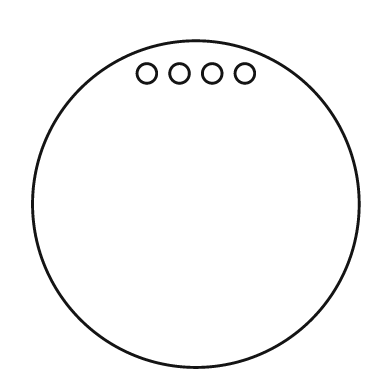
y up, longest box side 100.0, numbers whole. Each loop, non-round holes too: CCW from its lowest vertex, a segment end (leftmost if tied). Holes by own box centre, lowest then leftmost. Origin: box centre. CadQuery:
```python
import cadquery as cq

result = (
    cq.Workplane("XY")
    .moveTo(0.0, 0.0)
    .circle(50.0)
    .moveTo(-15.0, 40.0)
    .circle(3.0)
    .moveTo(-5.0, 40.0)
    .circle(3.0)
    .moveTo(5.0, 40.0)
    .circle(3.0)
    .moveTo(15.0, 40.0)
    .circle(3.0)
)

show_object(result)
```